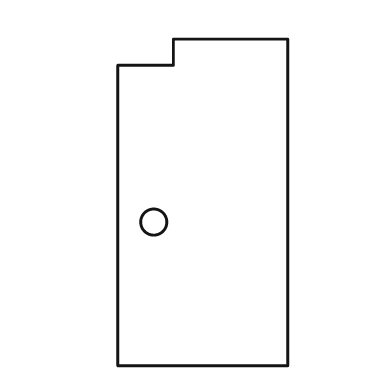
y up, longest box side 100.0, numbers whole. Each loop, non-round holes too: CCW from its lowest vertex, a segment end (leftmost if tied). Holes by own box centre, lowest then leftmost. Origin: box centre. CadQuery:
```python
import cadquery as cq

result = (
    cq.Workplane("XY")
    .moveTo(-26.0, -50.0)
    .lineTo(26.0, -50.0)
    .lineTo(26.0, 50.0)
    .lineTo(-9.0, 50.0)
    .lineTo(-9.0, 42.0)
    .lineTo(-26.0, 42.0)
    .close()
    .moveTo(-15.0, -6.0)
    .circle(4.0)
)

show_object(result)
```